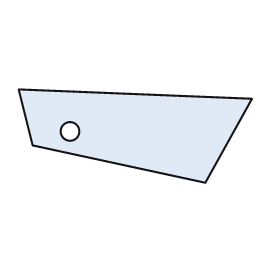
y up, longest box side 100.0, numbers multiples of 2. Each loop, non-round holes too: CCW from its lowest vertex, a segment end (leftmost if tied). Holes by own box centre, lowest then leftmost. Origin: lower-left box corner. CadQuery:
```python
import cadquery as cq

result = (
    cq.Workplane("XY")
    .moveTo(80.0, 0.0)
    .lineTo(100.0, 36.0)
    .lineTo(0.0, 40.0)
    .lineTo(6.0, 16.0)
    .close()
    .moveTo(22.0, 22.0)
    .circle(4.0)
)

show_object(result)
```